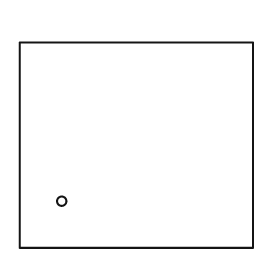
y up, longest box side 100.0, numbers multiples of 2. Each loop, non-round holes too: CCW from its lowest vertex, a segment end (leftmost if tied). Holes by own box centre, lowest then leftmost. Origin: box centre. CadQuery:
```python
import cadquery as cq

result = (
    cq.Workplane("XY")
    .moveTo(-50.0, -44.0)
    .lineTo(50.0, -44.0)
    .lineTo(50.0, 44.0)
    .lineTo(-50.0, 44.0)
    .close()
    .moveTo(-32.0, -24.0)
    .circle(2.0)
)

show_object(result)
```